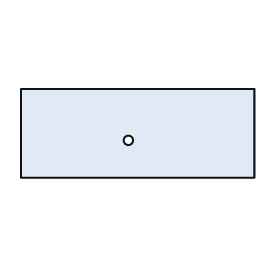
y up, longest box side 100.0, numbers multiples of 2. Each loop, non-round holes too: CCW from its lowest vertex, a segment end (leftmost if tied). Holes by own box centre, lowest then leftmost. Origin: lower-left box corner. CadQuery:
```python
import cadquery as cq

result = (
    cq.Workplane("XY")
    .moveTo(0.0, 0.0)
    .lineTo(100.0, 0.0)
    .lineTo(100.0, 38.0)
    .lineTo(0.0, 38.0)
    .close()
    .moveTo(46.0, 16.0)
    .circle(2.0)
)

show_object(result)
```